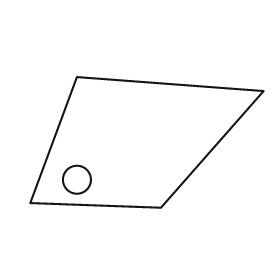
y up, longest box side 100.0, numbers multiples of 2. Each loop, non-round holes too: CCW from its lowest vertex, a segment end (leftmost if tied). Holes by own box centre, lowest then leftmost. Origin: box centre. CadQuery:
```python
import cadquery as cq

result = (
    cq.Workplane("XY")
    .moveTo(6.0, -28.0)
    .lineTo(50.0, 22.0)
    .lineTo(-30.0, 28.0)
    .lineTo(-50.0, -26.0)
    .close()
    .moveTo(-30.0, -16.0)
    .circle(6.0)
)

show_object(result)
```